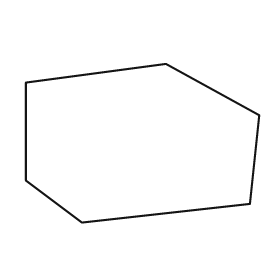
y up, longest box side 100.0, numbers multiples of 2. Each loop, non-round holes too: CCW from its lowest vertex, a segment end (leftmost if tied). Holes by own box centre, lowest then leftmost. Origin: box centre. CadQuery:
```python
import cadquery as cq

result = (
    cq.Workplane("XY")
    .moveTo(-26.0, -34.0)
    .lineTo(46.0, -26.0)
    .lineTo(50.0, 12.0)
    .lineTo(10.0, 34.0)
    .lineTo(-50.0, 26.0)
    .lineTo(-50.0, -16.0)
    .close()
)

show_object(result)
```